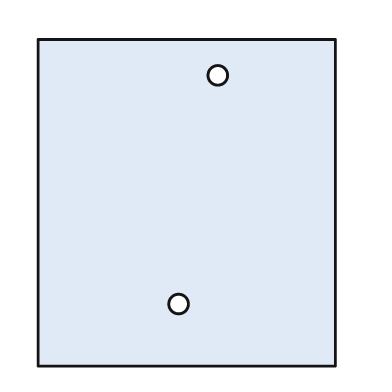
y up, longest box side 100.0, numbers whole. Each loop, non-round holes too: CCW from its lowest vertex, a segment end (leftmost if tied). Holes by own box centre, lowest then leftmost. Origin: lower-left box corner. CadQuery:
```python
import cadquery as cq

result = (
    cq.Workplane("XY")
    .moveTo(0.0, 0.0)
    .lineTo(91.0, 0.0)
    .lineTo(91.0, 100.0)
    .lineTo(0.0, 100.0)
    .close()
    .moveTo(43.0, 19.0)
    .circle(3.0)
    .moveTo(55.0, 89.0)
    .circle(3.0)
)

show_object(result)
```